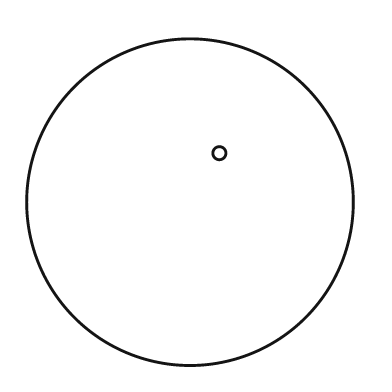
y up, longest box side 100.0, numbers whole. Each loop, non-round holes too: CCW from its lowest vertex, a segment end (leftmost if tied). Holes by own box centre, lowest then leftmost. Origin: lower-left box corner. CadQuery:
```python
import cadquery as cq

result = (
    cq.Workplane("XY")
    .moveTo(50.0, 50.0)
    .circle(50.0)
    .moveTo(59.0, 65.0)
    .circle(2.0)
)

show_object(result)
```